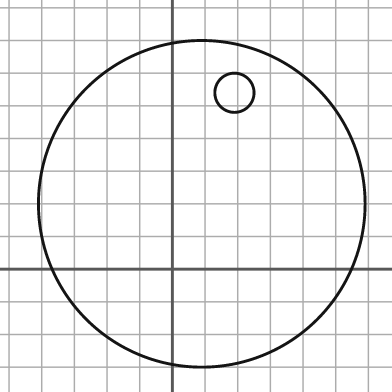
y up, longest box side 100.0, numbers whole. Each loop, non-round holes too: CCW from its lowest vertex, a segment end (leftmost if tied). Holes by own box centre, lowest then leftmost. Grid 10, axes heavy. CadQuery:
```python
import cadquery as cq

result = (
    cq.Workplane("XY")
    .moveTo(9.0, 20.0)
    .circle(50.0)
    .moveTo(19.0, 54.0)
    .circle(6.0)
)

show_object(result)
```